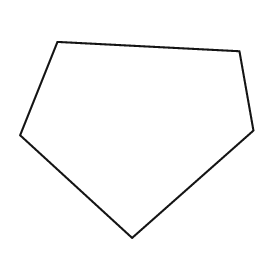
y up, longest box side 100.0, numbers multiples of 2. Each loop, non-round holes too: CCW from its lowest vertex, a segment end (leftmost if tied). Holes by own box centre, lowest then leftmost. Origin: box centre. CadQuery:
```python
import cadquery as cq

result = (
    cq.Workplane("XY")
    .moveTo(-2.0, -42.0)
    .lineTo(50.0, 4.0)
    .lineTo(44.0, 38.0)
    .lineTo(-34.0, 42.0)
    .lineTo(-50.0, 2.0)
    .close()
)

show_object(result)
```